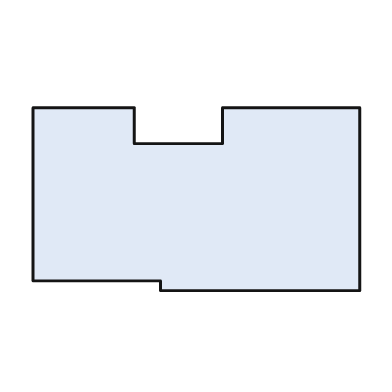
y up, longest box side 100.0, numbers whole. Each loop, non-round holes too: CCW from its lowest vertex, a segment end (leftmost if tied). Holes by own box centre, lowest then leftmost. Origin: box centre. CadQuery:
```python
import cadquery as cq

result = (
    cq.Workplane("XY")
    .moveTo(-11.0, -28.0)
    .lineTo(50.0, -28.0)
    .lineTo(50.0, 28.0)
    .lineTo(8.0, 28.0)
    .lineTo(8.0, 17.0)
    .lineTo(-19.0, 17.0)
    .lineTo(-19.0, 28.0)
    .lineTo(-50.0, 28.0)
    .lineTo(-50.0, -25.0)
    .lineTo(-11.0, -25.0)
    .close()
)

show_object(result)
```